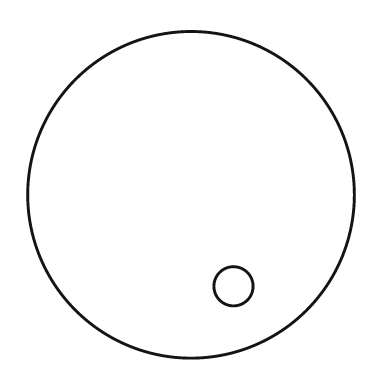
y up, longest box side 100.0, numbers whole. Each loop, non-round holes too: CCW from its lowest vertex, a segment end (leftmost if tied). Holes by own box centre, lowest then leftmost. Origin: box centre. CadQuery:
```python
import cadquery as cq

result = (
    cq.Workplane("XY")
    .moveTo(0.0, 0.0)
    .circle(50.0)
    .moveTo(13.0, -28.0)
    .circle(6.0)
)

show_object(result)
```